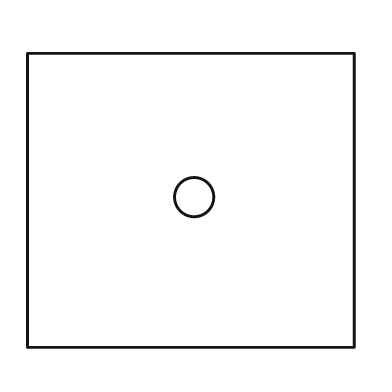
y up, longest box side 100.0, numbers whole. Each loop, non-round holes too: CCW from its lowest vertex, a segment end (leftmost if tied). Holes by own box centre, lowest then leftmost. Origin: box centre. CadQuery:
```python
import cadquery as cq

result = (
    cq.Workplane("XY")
    .moveTo(-50.0, -45.0)
    .lineTo(50.0, -45.0)
    .lineTo(50.0, 45.0)
    .lineTo(-50.0, 45.0)
    .close()
    .moveTo(1.0, 1.0)
    .circle(6.0)
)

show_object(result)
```